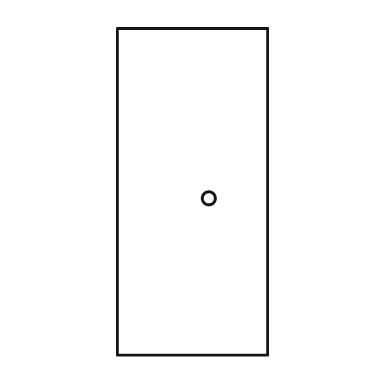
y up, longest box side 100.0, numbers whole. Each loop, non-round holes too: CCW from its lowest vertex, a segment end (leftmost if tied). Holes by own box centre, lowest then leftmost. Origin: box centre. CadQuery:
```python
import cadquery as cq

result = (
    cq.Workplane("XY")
    .moveTo(-23.0, -50.0)
    .lineTo(23.0, -50.0)
    .lineTo(23.0, 50.0)
    .lineTo(-23.0, 50.0)
    .close()
    .moveTo(5.0, -2.0)
    .circle(2.0)
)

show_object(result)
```